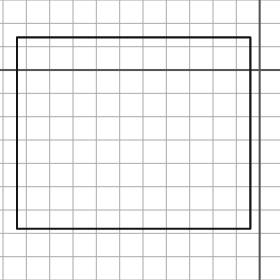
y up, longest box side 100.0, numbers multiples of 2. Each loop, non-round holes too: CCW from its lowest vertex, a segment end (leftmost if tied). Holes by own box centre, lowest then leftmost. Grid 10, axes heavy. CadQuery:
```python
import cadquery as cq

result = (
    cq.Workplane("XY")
    .moveTo(-104.0, -68.0)
    .lineTo(-4.0, -68.0)
    .lineTo(-4.0, 14.0)
    .lineTo(-104.0, 14.0)
    .close()
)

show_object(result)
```